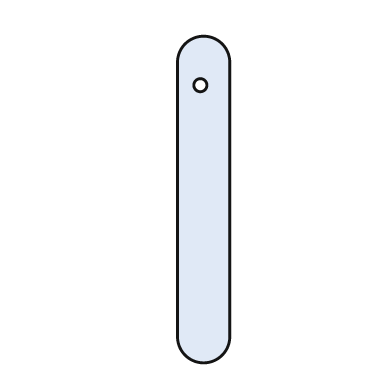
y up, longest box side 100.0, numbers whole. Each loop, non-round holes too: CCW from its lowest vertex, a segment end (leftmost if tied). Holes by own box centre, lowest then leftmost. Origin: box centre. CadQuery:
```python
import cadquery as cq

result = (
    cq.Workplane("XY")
    .moveTo(-8.0, -42.0)
    .threePointArc((0.0, -50.0), (8.0, -42.0))
    .lineTo(8.0, 42.0)
    .threePointArc((0.0, 50.0), (-8.0, 42.0))
    .close()
    .moveTo(-1.0, 35.0)
    .circle(2.0)
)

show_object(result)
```